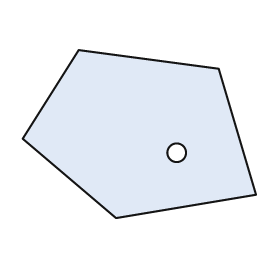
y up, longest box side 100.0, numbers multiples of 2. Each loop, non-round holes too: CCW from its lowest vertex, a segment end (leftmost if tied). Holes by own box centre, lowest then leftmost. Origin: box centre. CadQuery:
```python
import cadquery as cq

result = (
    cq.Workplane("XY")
    .moveTo(-10.0, -36.0)
    .lineTo(50.0, -26.0)
    .lineTo(34.0, 28.0)
    .lineTo(-26.0, 36.0)
    .lineTo(-50.0, -2.0)
    .close()
    .moveTo(16.0, -8.0)
    .circle(4.0)
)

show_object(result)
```